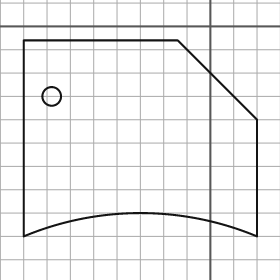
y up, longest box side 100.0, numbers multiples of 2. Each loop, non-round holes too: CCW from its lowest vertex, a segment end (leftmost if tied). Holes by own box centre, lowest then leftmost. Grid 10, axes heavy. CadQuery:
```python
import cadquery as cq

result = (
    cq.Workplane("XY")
    .moveTo(-80.0, -90.0)
    .threePointArc((-30.0, -80.0), (20.0, -90.0))
    .lineTo(20.0, -40.0)
    .lineTo(-14.0, -6.0)
    .lineTo(-80.0, -6.0)
    .close()
    .moveTo(-68.0, -30.0)
    .circle(4.0)
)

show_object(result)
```